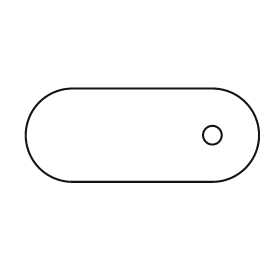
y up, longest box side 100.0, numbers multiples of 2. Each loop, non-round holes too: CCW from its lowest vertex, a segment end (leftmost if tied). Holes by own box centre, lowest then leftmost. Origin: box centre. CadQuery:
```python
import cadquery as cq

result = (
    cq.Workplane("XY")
    .moveTo(-30.0, -20.0)
    .lineTo(30.0, -20.0)
    .threePointArc((50.0, 0.0), (30.0, 20.0))
    .lineTo(-30.0, 20.0)
    .threePointArc((-50.0, 0.0), (-30.0, -20.0))
    .close()
    .moveTo(30.0, 0.0)
    .circle(4.0)
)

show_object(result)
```